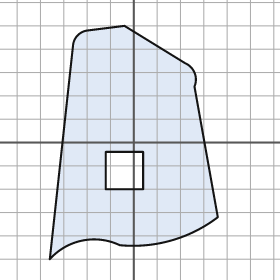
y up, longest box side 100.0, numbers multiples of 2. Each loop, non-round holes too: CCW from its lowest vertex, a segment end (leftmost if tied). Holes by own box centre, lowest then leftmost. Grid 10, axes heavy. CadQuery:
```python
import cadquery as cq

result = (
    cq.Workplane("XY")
    .moveTo(-36.0, -50.0)
    .threePointArc((-22.0, -42.0), (-6.0, -44.0))
    .threePointArc((16.0, -42.0), (36.0, -32.0))
    .lineTo(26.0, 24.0)
    .threePointArc((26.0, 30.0), (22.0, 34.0))
    .lineTo(-4.0, 50.0)
    .lineTo(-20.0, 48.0)
    .threePointArc((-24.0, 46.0), (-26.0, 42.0))
    .close()
    .moveTo(-12.0, -20.0)
    .lineTo(4.0, -20.0)
    .lineTo(4.0, -4.0)
    .lineTo(-12.0, -4.0)
    .close()
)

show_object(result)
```